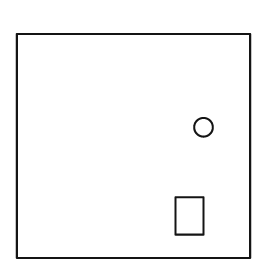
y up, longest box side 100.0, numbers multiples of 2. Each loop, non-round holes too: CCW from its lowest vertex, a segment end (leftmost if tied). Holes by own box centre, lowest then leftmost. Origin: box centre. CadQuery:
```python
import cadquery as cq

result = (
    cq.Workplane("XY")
    .moveTo(-50.0, -48.0)
    .lineTo(50.0, -48.0)
    .lineTo(50.0, 48.0)
    .lineTo(-50.0, 48.0)
    .close()
    .moveTo(18.0, -38.0)
    .lineTo(30.0, -38.0)
    .lineTo(30.0, -22.0)
    .lineTo(18.0, -22.0)
    .close()
    .moveTo(30.0, 8.0)
    .circle(4.0)
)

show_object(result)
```